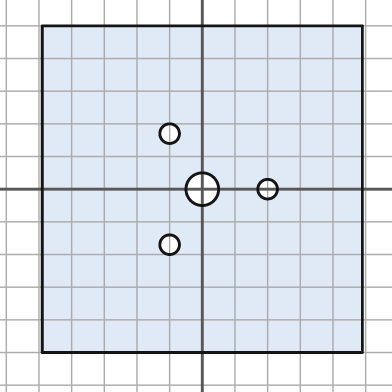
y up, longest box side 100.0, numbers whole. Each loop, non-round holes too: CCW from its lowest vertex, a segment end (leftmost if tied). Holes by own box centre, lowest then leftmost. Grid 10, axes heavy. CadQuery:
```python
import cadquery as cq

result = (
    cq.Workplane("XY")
    .moveTo(-49.0, -50.0)
    .lineTo(49.0, -50.0)
    .lineTo(49.0, 50.0)
    .lineTo(-49.0, 50.0)
    .close()
    .moveTo(-10.0, -17.0)
    .circle(3.0)
    .moveTo(0.0, 0.0)
    .circle(5.0)
    .moveTo(20.0, 0.0)
    .circle(3.0)
    .moveTo(-10.0, 17.0)
    .circle(3.0)
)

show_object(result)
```